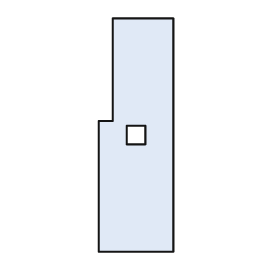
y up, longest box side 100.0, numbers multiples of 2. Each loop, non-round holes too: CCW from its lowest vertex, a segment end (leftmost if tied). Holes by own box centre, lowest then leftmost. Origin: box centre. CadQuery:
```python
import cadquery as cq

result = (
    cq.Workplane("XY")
    .moveTo(-16.0, -50.0)
    .lineTo(16.0, -50.0)
    .lineTo(16.0, 50.0)
    .lineTo(-10.0, 50.0)
    .lineTo(-10.0, 6.0)
    .lineTo(-16.0, 6.0)
    .close()
    .moveTo(-4.0, -4.0)
    .lineTo(4.0, -4.0)
    .lineTo(4.0, 4.0)
    .lineTo(-4.0, 4.0)
    .close()
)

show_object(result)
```